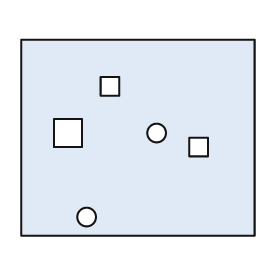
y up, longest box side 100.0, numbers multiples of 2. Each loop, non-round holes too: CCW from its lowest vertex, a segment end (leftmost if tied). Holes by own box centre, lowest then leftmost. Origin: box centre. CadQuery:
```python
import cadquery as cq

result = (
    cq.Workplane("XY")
    .moveTo(-50.0, -42.0)
    .lineTo(50.0, -42.0)
    .lineTo(50.0, 42.0)
    .lineTo(-50.0, 42.0)
    .close()
    .moveTo(-22.0, -34.0)
    .circle(4.0)
    .moveTo(22.0, -8.0)
    .lineTo(30.0, -8.0)
    .lineTo(30.0, 0.0)
    .lineTo(22.0, 0.0)
    .close()
    .moveTo(-36.0, -4.0)
    .lineTo(-24.0, -4.0)
    .lineTo(-24.0, 8.0)
    .lineTo(-36.0, 8.0)
    .close()
    .moveTo(8.0, 2.0)
    .circle(4.0)
    .moveTo(-16.0, 18.0)
    .lineTo(-8.0, 18.0)
    .lineTo(-8.0, 26.0)
    .lineTo(-16.0, 26.0)
    .close()
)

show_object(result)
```